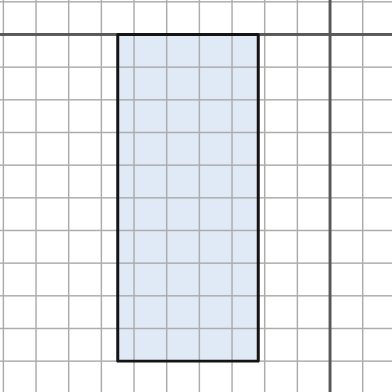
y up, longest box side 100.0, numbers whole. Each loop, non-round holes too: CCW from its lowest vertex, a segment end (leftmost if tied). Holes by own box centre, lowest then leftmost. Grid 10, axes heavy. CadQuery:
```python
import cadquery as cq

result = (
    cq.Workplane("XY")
    .moveTo(-65.0, -100.0)
    .lineTo(-22.0, -100.0)
    .lineTo(-22.0, 0.0)
    .lineTo(-65.0, 0.0)
    .close()
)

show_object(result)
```